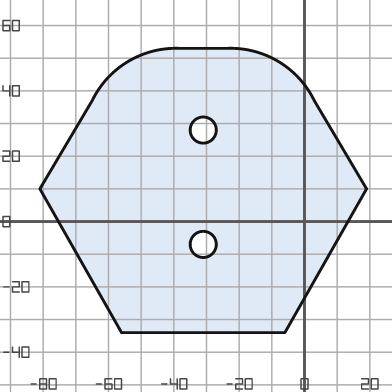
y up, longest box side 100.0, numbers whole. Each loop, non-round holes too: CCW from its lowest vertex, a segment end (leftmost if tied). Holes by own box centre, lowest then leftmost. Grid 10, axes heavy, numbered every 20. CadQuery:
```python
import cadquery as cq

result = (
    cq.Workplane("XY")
    .moveTo(-56.0, -34.0)
    .lineTo(-6.0, -34.0)
    .lineTo(19.0, 10.0)
    .lineTo(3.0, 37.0)
    .threePointArc((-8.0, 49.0), (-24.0, 53.0))
    .lineTo(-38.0, 53.0)
    .threePointArc((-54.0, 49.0), (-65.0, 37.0))
    .lineTo(-81.0, 10.0)
    .close()
    .moveTo(-31.0, -7.0)
    .circle(4.0)
    .moveTo(-31.0, 28.0)
    .circle(4.0)
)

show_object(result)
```